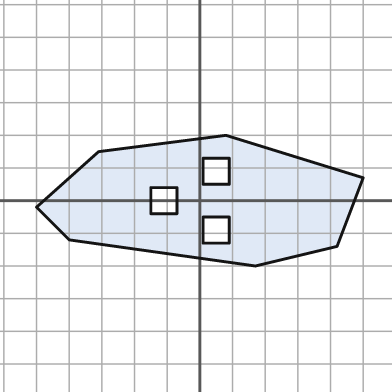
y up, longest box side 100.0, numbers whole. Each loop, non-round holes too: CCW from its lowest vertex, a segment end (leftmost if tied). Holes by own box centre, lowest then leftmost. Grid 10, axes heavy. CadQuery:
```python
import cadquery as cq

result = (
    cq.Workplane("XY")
    .moveTo(17.0, -20.0)
    .lineTo(42.0, -14.0)
    .lineTo(50.0, 7.0)
    .lineTo(8.0, 20.0)
    .lineTo(-31.0, 15.0)
    .lineTo(-50.0, -2.0)
    .lineTo(-40.0, -12.0)
    .close()
    .moveTo(1.0, -13.0)
    .lineTo(9.0, -13.0)
    .lineTo(9.0, -5.0)
    .lineTo(1.0, -5.0)
    .close()
    .moveTo(-15.0, -4.0)
    .lineTo(-7.0, -4.0)
    .lineTo(-7.0, 4.0)
    .lineTo(-15.0, 4.0)
    .close()
    .moveTo(1.0, 5.0)
    .lineTo(9.0, 5.0)
    .lineTo(9.0, 13.0)
    .lineTo(1.0, 13.0)
    .close()
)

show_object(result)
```